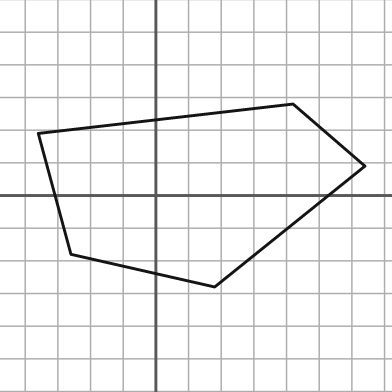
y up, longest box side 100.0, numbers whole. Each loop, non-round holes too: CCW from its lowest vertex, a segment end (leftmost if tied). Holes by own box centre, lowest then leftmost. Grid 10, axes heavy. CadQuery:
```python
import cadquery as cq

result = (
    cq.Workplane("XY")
    .moveTo(18.0, -28.0)
    .lineTo(64.0, 9.0)
    .lineTo(42.0, 28.0)
    .lineTo(-36.0, 19.0)
    .lineTo(-26.0, -18.0)
    .close()
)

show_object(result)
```